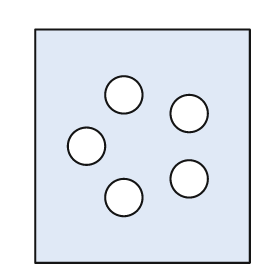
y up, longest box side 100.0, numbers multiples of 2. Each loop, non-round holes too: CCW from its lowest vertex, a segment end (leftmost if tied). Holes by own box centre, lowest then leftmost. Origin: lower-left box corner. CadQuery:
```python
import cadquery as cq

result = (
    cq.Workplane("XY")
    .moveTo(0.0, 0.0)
    .lineTo(92.0, 0.0)
    .lineTo(92.0, 100.0)
    .lineTo(0.0, 100.0)
    .close()
    .moveTo(38.0, 28.0)
    .circle(8.0)
    .moveTo(66.0, 36.0)
    .circle(8.0)
    .moveTo(22.0, 50.0)
    .circle(8.0)
    .moveTo(66.0, 64.0)
    .circle(8.0)
    .moveTo(38.0, 72.0)
    .circle(8.0)
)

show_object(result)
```